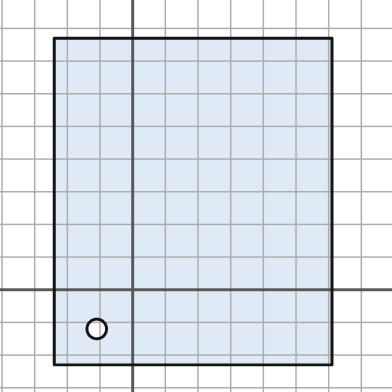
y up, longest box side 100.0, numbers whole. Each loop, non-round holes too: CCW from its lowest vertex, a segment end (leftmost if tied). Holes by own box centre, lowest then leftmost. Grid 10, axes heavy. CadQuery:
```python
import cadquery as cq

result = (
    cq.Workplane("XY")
    .moveTo(-24.0, -23.0)
    .lineTo(61.0, -23.0)
    .lineTo(61.0, 77.0)
    .lineTo(-24.0, 77.0)
    .close()
    .moveTo(-11.0, -12.0)
    .circle(3.0)
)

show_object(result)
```